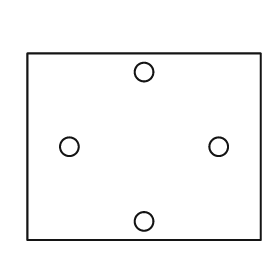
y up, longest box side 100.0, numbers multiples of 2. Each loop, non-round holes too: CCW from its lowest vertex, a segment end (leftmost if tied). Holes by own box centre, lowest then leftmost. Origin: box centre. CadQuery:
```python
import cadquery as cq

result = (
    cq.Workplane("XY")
    .moveTo(-50.0, -40.0)
    .lineTo(50.0, -40.0)
    .lineTo(50.0, 40.0)
    .lineTo(-50.0, 40.0)
    .close()
    .moveTo(0.0, -32.0)
    .circle(4.0)
    .moveTo(-32.0, 0.0)
    .circle(4.0)
    .moveTo(32.0, 0.0)
    .circle(4.0)
    .moveTo(0.0, 32.0)
    .circle(4.0)
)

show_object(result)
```